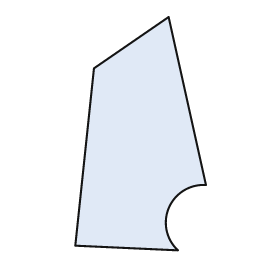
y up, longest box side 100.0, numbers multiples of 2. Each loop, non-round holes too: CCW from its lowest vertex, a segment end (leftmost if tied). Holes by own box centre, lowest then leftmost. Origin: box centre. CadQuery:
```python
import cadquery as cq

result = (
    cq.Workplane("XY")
    .moveTo(16.0, -50.0)
    .threePointArc((12.0, -32.0), (28.0, -22.0))
    .lineTo(12.0, 50.0)
    .lineTo(-20.0, 28.0)
    .lineTo(-28.0, -48.0)
    .close()
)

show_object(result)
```